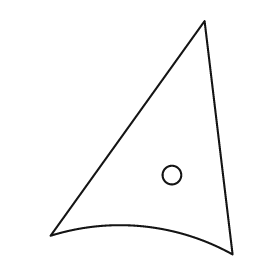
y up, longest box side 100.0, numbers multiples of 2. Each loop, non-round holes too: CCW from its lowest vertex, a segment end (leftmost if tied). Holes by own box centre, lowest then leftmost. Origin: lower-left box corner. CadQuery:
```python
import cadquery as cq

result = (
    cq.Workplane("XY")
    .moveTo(78.0, 0.0)
    .lineTo(66.0, 100.0)
    .lineTo(0.0, 8.0)
    .threePointArc((40.0, 12.0), (78.0, 0.0))
    .close()
    .moveTo(52.0, 34.0)
    .circle(4.0)
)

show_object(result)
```